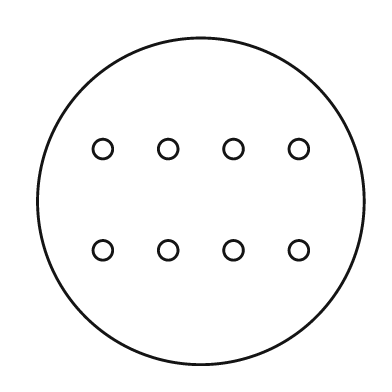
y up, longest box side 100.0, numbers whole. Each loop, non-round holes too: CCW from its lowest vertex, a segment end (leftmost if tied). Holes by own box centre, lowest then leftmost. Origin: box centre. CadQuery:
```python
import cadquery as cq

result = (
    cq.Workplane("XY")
    .moveTo(0.0, 0.0)
    .circle(50.0)
    .moveTo(-30.0, -15.0)
    .circle(3.0)
    .moveTo(-10.0, -15.0)
    .circle(3.0)
    .moveTo(10.0, -15.0)
    .circle(3.0)
    .moveTo(30.0, -15.0)
    .circle(3.0)
    .moveTo(-30.0, 16.0)
    .circle(3.0)
    .moveTo(-10.0, 16.0)
    .circle(3.0)
    .moveTo(10.0, 16.0)
    .circle(3.0)
    .moveTo(30.0, 16.0)
    .circle(3.0)
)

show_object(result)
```